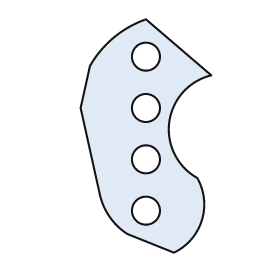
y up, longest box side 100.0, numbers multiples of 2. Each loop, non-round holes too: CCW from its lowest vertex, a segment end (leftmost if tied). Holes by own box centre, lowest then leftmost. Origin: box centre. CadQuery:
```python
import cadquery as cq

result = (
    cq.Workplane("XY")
    .moveTo(12.0, -50.0)
    .threePointArc((24.0, -36.0), (22.0, -18.0))
    .threePointArc((10.0, 6.0), (28.0, 26.0))
    .lineTo(0.0, 50.0)
    .threePointArc((-14.0, 42.0), (-24.0, 30.0))
    .lineTo(-28.0, 12.0)
    .lineTo(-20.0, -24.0)
    .threePointArc((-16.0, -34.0), (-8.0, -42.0))
    .close()
    .moveTo(0.0, -32.0)
    .circle(6.0)
    .moveTo(0.0, -10.0)
    .circle(6.0)
    .moveTo(0.0, 12.0)
    .circle(6.0)
    .moveTo(0.0, 34.0)
    .circle(6.0)
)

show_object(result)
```